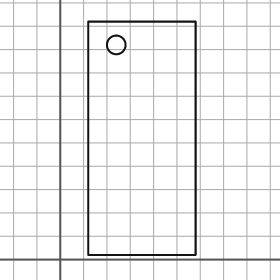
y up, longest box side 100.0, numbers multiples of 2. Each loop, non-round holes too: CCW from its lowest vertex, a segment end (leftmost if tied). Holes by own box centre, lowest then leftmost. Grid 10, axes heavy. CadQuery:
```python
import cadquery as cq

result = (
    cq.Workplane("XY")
    .moveTo(12.0, 2.0)
    .lineTo(58.0, 2.0)
    .lineTo(58.0, 102.0)
    .lineTo(12.0, 102.0)
    .close()
    .moveTo(24.0, 92.0)
    .circle(4.0)
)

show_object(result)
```